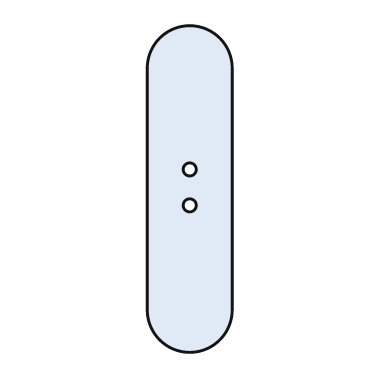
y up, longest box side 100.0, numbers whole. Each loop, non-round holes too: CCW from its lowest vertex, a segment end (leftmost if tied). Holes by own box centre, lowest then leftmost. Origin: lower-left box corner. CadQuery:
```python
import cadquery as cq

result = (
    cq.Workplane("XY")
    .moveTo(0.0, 13.0)
    .threePointArc((13.0, 0.0), (26.0, 13.0))
    .lineTo(26.0, 87.0)
    .threePointArc((13.0, 100.0), (0.0, 87.0))
    .close()
    .moveTo(13.0, 45.0)
    .circle(2.0)
    .moveTo(13.0, 56.0)
    .circle(2.0)
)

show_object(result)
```